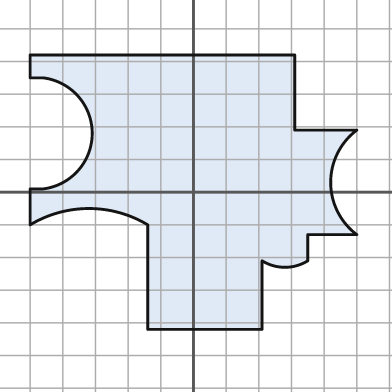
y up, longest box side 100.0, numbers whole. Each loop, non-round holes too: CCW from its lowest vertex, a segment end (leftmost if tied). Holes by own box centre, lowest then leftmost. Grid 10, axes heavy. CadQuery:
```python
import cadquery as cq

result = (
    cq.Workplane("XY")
    .moveTo(-14.0, -42.0)
    .lineTo(21.0, -42.0)
    .lineTo(21.0, -21.0)
    .threePointArc((28.0, -23.0), (35.0, -21.0))
    .lineTo(35.0, -13.0)
    .lineTo(50.0, -13.0)
    .threePointArc((42.0, 3.0), (50.0, 19.0))
    .lineTo(31.0, 19.0)
    .lineTo(31.0, 42.0)
    .lineTo(-50.0, 42.0)
    .lineTo(-50.0, 35.0)
    .lineTo(-46.0, 35.0)
    .threePointArc((-31.0, 18.0), (-46.0, 1.0))
    .lineTo(-50.0, 1.0)
    .lineTo(-50.0, -10.0)
    .threePointArc((-32.0, -5.0), (-14.0, -10.0))
    .close()
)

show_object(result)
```